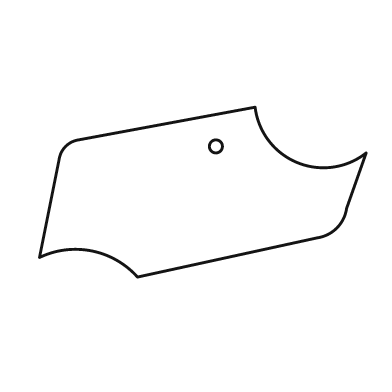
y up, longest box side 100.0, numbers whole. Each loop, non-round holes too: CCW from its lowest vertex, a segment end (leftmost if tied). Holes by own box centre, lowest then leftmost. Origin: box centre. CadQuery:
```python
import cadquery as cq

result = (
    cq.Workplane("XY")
    .moveTo(-20.0, -26.0)
    .lineTo(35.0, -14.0)
    .threePointArc((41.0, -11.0), (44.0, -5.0))
    .lineTo(50.0, 12.0)
    .threePointArc((29.0, 9.0), (16.0, 26.0))
    .lineTo(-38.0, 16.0)
    .threePointArc((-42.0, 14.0), (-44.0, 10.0))
    .lineTo(-50.0, -20.0)
    .threePointArc((-34.0, -18.0), (-20.0, -26.0))
    .close()
    .moveTo(4.0, 14.0)
    .circle(2.0)
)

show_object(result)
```